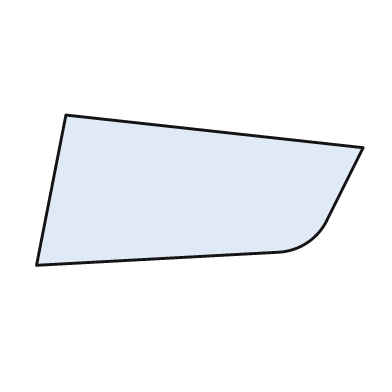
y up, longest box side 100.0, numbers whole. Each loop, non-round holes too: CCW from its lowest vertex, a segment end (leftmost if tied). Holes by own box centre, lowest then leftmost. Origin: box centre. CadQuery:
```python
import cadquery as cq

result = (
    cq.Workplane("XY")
    .moveTo(-50.0, -23.0)
    .lineTo(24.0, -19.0)
    .threePointArc((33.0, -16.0), (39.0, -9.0))
    .lineTo(50.0, 13.0)
    .lineTo(-41.0, 23.0)
    .close()
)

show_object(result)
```